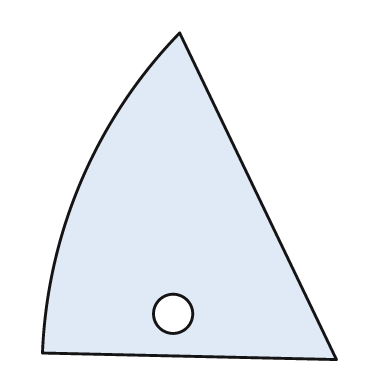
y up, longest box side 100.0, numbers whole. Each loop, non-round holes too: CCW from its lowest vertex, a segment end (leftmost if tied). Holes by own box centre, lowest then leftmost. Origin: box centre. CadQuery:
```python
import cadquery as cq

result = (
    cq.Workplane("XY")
    .moveTo(45.0, -50.0)
    .lineTo(-3.0, 50.0)
    .threePointArc((-33.0, 5.0), (-45.0, -48.0))
    .close()
    .moveTo(-5.0, -36.0)
    .circle(6.0)
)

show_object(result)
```